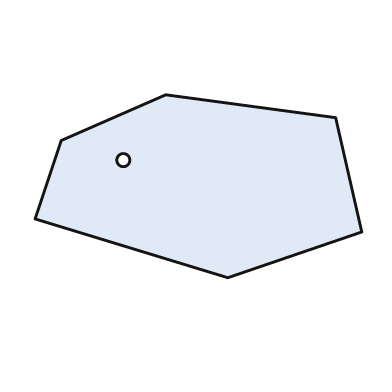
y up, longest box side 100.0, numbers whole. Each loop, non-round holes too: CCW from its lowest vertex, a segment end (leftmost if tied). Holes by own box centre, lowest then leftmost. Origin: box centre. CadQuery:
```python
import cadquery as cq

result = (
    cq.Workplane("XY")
    .moveTo(9.0, -28.0)
    .lineTo(50.0, -14.0)
    .lineTo(42.0, 21.0)
    .lineTo(-10.0, 28.0)
    .lineTo(-42.0, 14.0)
    .lineTo(-50.0, -10.0)
    .close()
    .moveTo(-23.0, 8.0)
    .circle(2.0)
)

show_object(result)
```